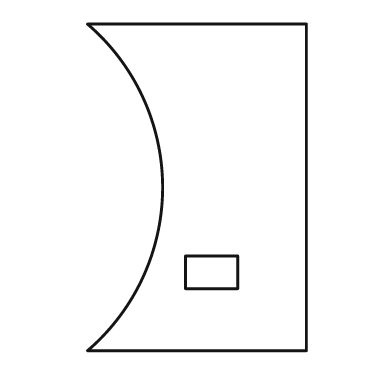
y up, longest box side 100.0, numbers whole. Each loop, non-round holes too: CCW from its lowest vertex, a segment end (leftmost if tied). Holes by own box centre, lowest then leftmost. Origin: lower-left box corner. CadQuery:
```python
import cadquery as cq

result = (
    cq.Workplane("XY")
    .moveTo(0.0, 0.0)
    .lineTo(67.0, 0.0)
    .lineTo(67.0, 100.0)
    .lineTo(0.0, 100.0)
    .threePointArc((23.0, 50.0), (0.0, 0.0))
    .close()
    .moveTo(30.0, 19.0)
    .lineTo(46.0, 19.0)
    .lineTo(46.0, 29.0)
    .lineTo(30.0, 29.0)
    .close()
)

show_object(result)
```